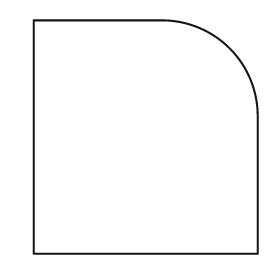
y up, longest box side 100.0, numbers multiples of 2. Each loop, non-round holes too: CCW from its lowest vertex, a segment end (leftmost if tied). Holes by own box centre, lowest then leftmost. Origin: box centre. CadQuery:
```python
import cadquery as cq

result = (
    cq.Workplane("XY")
    .moveTo(-48.0, -50.0)
    .lineTo(48.0, -50.0)
    .lineTo(48.0, 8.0)
    .threePointArc((36.0, 38.0), (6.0, 50.0))
    .lineTo(-48.0, 50.0)
    .close()
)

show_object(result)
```